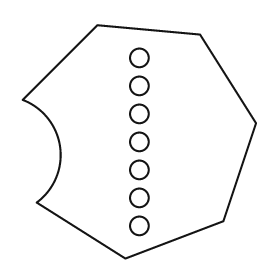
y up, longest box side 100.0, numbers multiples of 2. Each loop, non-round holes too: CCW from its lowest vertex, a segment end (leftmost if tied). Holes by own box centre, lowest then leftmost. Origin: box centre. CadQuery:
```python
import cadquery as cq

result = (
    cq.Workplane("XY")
    .moveTo(-6.0, -50.0)
    .lineTo(36.0, -34.0)
    .lineTo(50.0, 8.0)
    .lineTo(26.0, 46.0)
    .lineTo(-18.0, 50.0)
    .lineTo(-50.0, 18.0)
    .threePointArc((-34.0, -2.0), (-44.0, -26.0))
    .close()
    .moveTo(0.0, -36.0)
    .circle(4.0)
    .moveTo(0.0, -24.0)
    .circle(4.0)
    .moveTo(0.0, -12.0)
    .circle(4.0)
    .moveTo(0.0, 0.0)
    .circle(4.0)
    .moveTo(0.0, 12.0)
    .circle(4.0)
    .moveTo(0.0, 24.0)
    .circle(4.0)
    .moveTo(0.0, 36.0)
    .circle(4.0)
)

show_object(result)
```